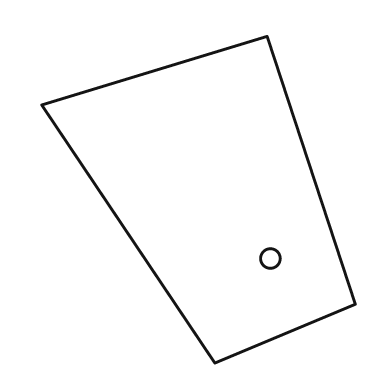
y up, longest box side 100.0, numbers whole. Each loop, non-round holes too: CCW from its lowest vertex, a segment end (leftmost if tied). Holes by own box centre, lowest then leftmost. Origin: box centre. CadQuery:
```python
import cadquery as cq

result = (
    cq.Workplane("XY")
    .moveTo(5.0, -50.0)
    .lineTo(48.0, -32.0)
    .lineTo(21.0, 50.0)
    .lineTo(-48.0, 29.0)
    .close()
    .moveTo(22.0, -18.0)
    .circle(3.0)
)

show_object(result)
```